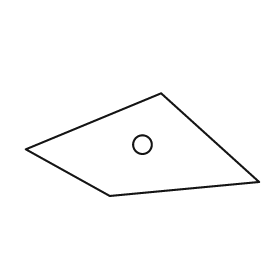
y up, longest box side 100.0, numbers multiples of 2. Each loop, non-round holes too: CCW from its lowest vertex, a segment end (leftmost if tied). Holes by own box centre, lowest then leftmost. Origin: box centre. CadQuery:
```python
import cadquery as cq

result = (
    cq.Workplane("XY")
    .moveTo(-14.0, -22.0)
    .lineTo(50.0, -16.0)
    .lineTo(8.0, 22.0)
    .lineTo(-50.0, -2.0)
    .close()
    .moveTo(0.0, 0.0)
    .circle(4.0)
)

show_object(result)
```